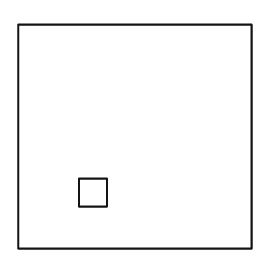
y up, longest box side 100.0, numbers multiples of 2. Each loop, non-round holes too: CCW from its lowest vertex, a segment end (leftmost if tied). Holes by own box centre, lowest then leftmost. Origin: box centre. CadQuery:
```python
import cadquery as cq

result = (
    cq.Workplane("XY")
    .moveTo(-50.0, -48.0)
    .lineTo(50.0, -48.0)
    .lineTo(50.0, 48.0)
    .lineTo(-50.0, 48.0)
    .close()
    .moveTo(-24.0, -30.0)
    .lineTo(-12.0, -30.0)
    .lineTo(-12.0, -18.0)
    .lineTo(-24.0, -18.0)
    .close()
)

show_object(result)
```